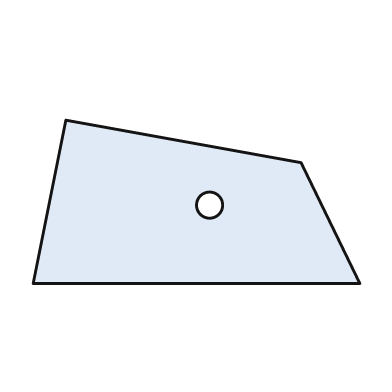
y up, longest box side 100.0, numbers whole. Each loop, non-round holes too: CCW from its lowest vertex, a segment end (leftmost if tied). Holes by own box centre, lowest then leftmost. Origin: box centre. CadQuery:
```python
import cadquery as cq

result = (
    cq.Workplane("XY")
    .moveTo(-50.0, -25.0)
    .lineTo(50.0, -25.0)
    .lineTo(32.0, 12.0)
    .lineTo(-40.0, 25.0)
    .close()
    .moveTo(4.0, -1.0)
    .circle(4.0)
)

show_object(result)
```